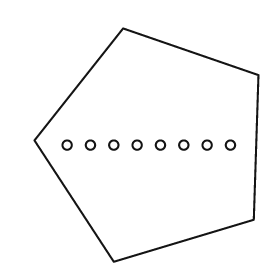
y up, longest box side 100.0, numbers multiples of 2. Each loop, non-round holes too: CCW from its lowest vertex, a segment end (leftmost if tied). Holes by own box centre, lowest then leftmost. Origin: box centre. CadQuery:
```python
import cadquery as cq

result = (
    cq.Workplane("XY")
    .moveTo(-14.0, -50.0)
    .lineTo(46.0, -32.0)
    .lineTo(48.0, 30.0)
    .lineTo(-10.0, 50.0)
    .lineTo(-48.0, 2.0)
    .close()
    .moveTo(-34.0, 0.0)
    .circle(2.0)
    .moveTo(-24.0, 0.0)
    .circle(2.0)
    .moveTo(-14.0, 0.0)
    .circle(2.0)
    .moveTo(-4.0, 0.0)
    .circle(2.0)
    .moveTo(6.0, 0.0)
    .circle(2.0)
    .moveTo(16.0, 0.0)
    .circle(2.0)
    .moveTo(26.0, 0.0)
    .circle(2.0)
    .moveTo(36.0, 0.0)
    .circle(2.0)
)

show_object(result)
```